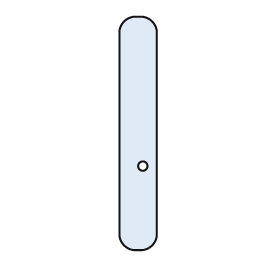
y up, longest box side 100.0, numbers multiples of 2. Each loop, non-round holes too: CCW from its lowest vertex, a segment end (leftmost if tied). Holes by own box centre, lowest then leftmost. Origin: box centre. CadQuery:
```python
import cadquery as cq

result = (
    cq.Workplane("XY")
    .moveTo(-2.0, -50.0)
    .lineTo(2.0, -50.0)
    .threePointArc((6.0, -48.0), (8.0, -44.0))
    .lineTo(8.0, 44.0)
    .threePointArc((6.0, 48.0), (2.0, 50.0))
    .lineTo(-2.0, 50.0)
    .threePointArc((-6.0, 48.0), (-8.0, 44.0))
    .lineTo(-8.0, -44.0)
    .threePointArc((-6.0, -48.0), (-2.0, -50.0))
    .close()
    .moveTo(2.0, -14.0)
    .circle(2.0)
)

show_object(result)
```